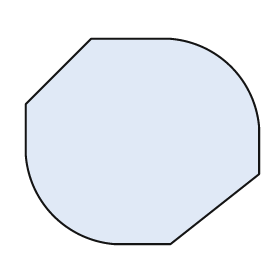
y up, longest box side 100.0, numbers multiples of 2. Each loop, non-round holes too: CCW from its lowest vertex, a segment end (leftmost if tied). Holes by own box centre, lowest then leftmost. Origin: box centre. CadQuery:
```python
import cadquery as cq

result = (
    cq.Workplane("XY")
    .moveTo(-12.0, -44.0)
    .lineTo(12.0, -44.0)
    .lineTo(50.0, -14.0)
    .lineTo(50.0, 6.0)
    .threePointArc((38.0, 32.0), (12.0, 44.0))
    .lineTo(-22.0, 44.0)
    .lineTo(-50.0, 16.0)
    .lineTo(-50.0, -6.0)
    .threePointArc((-38.0, -32.0), (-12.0, -44.0))
    .close()
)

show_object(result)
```